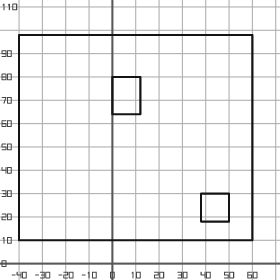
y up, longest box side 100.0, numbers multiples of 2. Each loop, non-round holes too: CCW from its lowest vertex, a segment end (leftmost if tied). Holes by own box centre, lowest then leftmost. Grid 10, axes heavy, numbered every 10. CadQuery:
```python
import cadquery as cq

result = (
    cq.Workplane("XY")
    .moveTo(-40.0, 10.0)
    .lineTo(60.0, 10.0)
    .lineTo(60.0, 98.0)
    .lineTo(-40.0, 98.0)
    .close()
    .moveTo(38.0, 18.0)
    .lineTo(50.0, 18.0)
    .lineTo(50.0, 30.0)
    .lineTo(38.0, 30.0)
    .close()
    .moveTo(0.0, 64.0)
    .lineTo(12.0, 64.0)
    .lineTo(12.0, 80.0)
    .lineTo(0.0, 80.0)
    .close()
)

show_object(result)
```